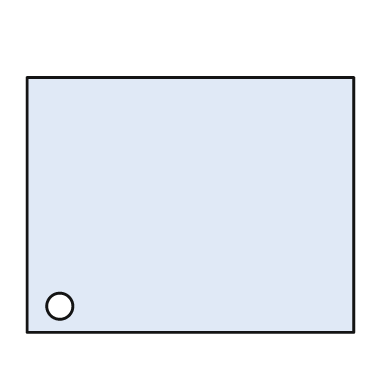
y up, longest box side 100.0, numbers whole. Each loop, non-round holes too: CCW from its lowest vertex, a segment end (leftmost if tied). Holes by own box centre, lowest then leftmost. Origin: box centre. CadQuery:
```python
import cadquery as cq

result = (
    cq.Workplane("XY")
    .moveTo(-50.0, -39.0)
    .lineTo(50.0, -39.0)
    .lineTo(50.0, 39.0)
    .lineTo(-50.0, 39.0)
    .close()
    .moveTo(-40.0, -31.0)
    .circle(4.0)
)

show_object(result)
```